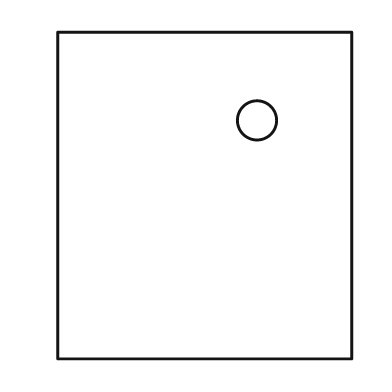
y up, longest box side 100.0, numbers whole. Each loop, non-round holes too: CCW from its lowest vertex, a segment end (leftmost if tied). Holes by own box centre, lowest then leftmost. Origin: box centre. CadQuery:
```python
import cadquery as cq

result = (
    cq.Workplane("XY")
    .moveTo(-45.0, -50.0)
    .lineTo(45.0, -50.0)
    .lineTo(45.0, 50.0)
    .lineTo(-45.0, 50.0)
    .close()
    .moveTo(16.0, 23.0)
    .circle(6.0)
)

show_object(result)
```